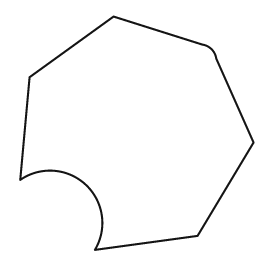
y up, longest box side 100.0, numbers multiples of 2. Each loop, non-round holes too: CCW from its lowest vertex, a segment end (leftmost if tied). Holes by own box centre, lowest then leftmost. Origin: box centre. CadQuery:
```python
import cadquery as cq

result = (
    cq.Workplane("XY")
    .moveTo(-18.0, -50.0)
    .lineTo(26.0, -44.0)
    .lineTo(50.0, -4.0)
    .lineTo(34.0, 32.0)
    .threePointArc((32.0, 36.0), (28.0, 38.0))
    .lineTo(-10.0, 50.0)
    .lineTo(-46.0, 24.0)
    .lineTo(-50.0, -20.0)
    .threePointArc((-22.0, -22.0), (-18.0, -50.0))
    .close()
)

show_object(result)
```